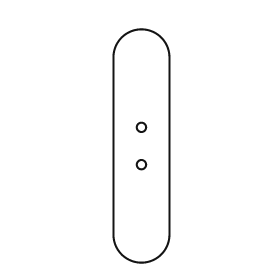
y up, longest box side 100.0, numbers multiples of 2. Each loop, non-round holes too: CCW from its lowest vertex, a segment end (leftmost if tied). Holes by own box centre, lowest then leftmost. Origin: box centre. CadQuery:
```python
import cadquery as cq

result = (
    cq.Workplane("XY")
    .moveTo(-12.0, -38.0)
    .threePointArc((0.0, -50.0), (12.0, -38.0))
    .lineTo(12.0, 38.0)
    .threePointArc((0.0, 50.0), (-12.0, 38.0))
    .close()
    .moveTo(0.0, -8.0)
    .circle(2.0)
    .moveTo(0.0, 8.0)
    .circle(2.0)
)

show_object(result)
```